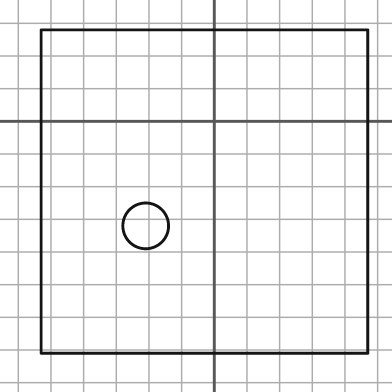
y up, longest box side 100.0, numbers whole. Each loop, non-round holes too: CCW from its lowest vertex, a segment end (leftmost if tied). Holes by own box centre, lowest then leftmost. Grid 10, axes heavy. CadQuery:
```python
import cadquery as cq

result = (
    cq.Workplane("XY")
    .moveTo(-53.0, -71.0)
    .lineTo(47.0, -71.0)
    .lineTo(47.0, 28.0)
    .lineTo(-53.0, 28.0)
    .close()
    .moveTo(-21.0, -32.0)
    .circle(7.0)
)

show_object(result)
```